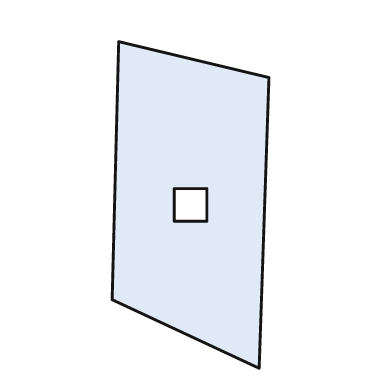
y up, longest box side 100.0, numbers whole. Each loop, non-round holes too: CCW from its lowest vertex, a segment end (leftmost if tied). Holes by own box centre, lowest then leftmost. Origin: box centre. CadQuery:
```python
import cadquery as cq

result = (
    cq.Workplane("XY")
    .moveTo(21.0, -50.0)
    .lineTo(24.0, 39.0)
    .lineTo(-22.0, 50.0)
    .lineTo(-24.0, -29.0)
    .close()
    .moveTo(-5.0, -5.0)
    .lineTo(5.0, -5.0)
    .lineTo(5.0, 5.0)
    .lineTo(-5.0, 5.0)
    .close()
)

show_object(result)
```